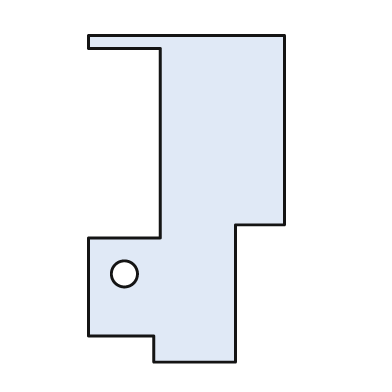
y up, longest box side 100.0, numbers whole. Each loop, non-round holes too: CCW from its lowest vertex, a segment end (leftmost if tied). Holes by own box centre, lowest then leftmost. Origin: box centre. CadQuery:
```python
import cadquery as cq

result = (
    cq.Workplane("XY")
    .moveTo(-10.0, -50.0)
    .lineTo(15.0, -50.0)
    .lineTo(15.0, -8.0)
    .lineTo(30.0, -8.0)
    .lineTo(30.0, 50.0)
    .lineTo(-30.0, 50.0)
    .lineTo(-30.0, 46.0)
    .lineTo(-8.0, 46.0)
    .lineTo(-8.0, -12.0)
    .lineTo(-30.0, -12.0)
    .lineTo(-30.0, -42.0)
    .lineTo(-10.0, -42.0)
    .close()
    .moveTo(-19.0, -23.0)
    .circle(4.0)
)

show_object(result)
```